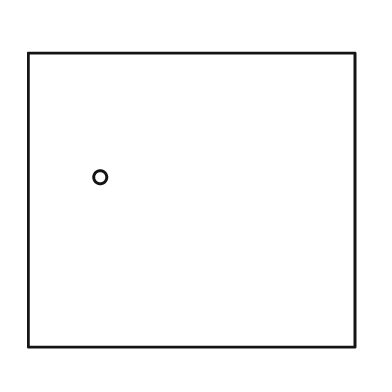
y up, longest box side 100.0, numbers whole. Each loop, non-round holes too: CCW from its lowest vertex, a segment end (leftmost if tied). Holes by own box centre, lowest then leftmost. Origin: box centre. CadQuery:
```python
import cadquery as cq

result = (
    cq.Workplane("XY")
    .moveTo(-50.0, -45.0)
    .lineTo(50.0, -45.0)
    .lineTo(50.0, 45.0)
    .lineTo(-50.0, 45.0)
    .close()
    .moveTo(-28.0, 7.0)
    .circle(2.0)
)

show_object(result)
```